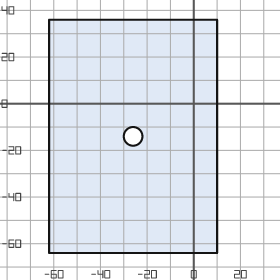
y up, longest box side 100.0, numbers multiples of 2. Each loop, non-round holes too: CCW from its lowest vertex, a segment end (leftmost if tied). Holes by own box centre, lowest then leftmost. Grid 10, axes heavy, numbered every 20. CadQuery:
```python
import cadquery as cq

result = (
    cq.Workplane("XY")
    .moveTo(-62.0, -64.0)
    .lineTo(10.0, -64.0)
    .lineTo(10.0, 36.0)
    .lineTo(-62.0, 36.0)
    .close()
    .moveTo(-26.0, -14.0)
    .circle(4.0)
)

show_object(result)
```